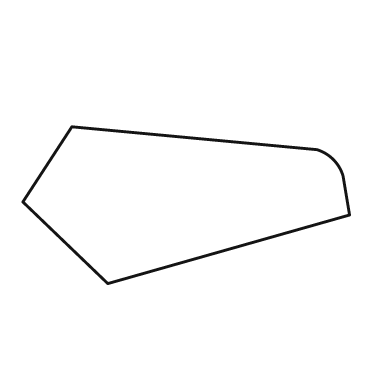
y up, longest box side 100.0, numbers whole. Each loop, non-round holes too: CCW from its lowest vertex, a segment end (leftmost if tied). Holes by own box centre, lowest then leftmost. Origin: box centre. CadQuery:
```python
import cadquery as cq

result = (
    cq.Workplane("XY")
    .moveTo(-24.0, -24.0)
    .lineTo(50.0, -3.0)
    .lineTo(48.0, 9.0)
    .threePointArc((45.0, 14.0), (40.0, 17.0))
    .lineTo(-35.0, 24.0)
    .lineTo(-50.0, 1.0)
    .close()
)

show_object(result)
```